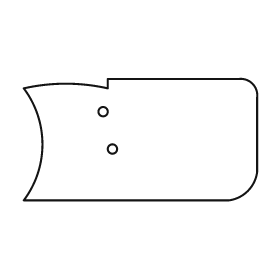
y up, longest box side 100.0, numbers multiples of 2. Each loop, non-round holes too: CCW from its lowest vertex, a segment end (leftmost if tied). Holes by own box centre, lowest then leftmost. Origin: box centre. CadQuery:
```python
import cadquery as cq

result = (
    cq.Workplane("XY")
    .moveTo(-50.0, -26.0)
    .lineTo(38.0, -26.0)
    .threePointArc((46.0, -22.0), (50.0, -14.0))
    .lineTo(50.0, 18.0)
    .threePointArc((48.0, 24.0), (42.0, 26.0))
    .lineTo(-14.0, 26.0)
    .lineTo(-14.0, 22.0)
    .threePointArc((-32.0, 24.0), (-50.0, 22.0))
    .threePointArc((-42.0, -2.0), (-50.0, -26.0))
    .close()
    .moveTo(-12.0, -4.0)
    .circle(2.0)
    .moveTo(-16.0, 12.0)
    .circle(2.0)
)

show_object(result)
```